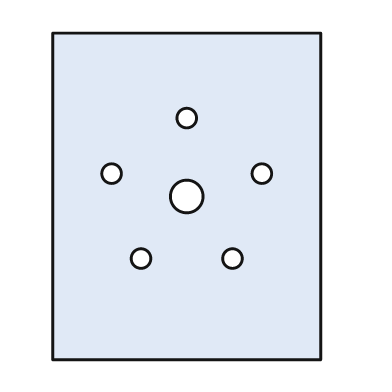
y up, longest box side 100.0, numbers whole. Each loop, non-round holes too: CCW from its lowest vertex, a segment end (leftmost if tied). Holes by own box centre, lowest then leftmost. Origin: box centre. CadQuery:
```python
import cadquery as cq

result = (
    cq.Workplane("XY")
    .moveTo(-41.0, -50.0)
    .lineTo(41.0, -50.0)
    .lineTo(41.0, 50.0)
    .lineTo(-41.0, 50.0)
    .close()
    .moveTo(-14.0, -19.0)
    .circle(3.0)
    .moveTo(14.0, -19.0)
    .circle(3.0)
    .moveTo(0.0, 0.0)
    .circle(5.0)
    .moveTo(-23.0, 7.0)
    .circle(3.0)
    .moveTo(23.0, 7.0)
    .circle(3.0)
    .moveTo(0.0, 24.0)
    .circle(3.0)
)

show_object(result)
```